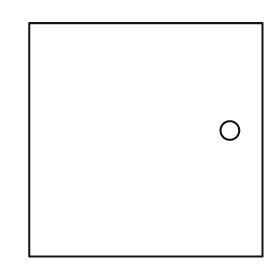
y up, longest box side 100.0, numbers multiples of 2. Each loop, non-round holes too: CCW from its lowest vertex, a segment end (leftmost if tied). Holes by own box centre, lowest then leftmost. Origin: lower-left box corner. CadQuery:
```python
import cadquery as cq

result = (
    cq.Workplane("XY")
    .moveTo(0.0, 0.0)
    .lineTo(100.0, 0.0)
    .lineTo(100.0, 100.0)
    .lineTo(0.0, 100.0)
    .close()
    .moveTo(86.0, 54.0)
    .circle(4.0)
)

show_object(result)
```